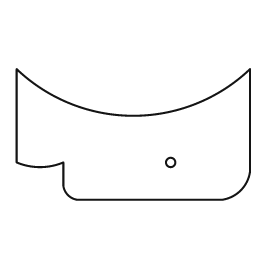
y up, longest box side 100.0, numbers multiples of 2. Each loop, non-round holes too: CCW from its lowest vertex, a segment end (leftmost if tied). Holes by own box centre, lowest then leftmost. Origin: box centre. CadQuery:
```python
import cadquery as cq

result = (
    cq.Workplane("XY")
    .moveTo(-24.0, -28.0)
    .lineTo(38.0, -28.0)
    .threePointArc((46.0, -24.0), (50.0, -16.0))
    .lineTo(50.0, 28.0)
    .threePointArc((0.0, 8.0), (-50.0, 28.0))
    .lineTo(-50.0, -12.0)
    .threePointArc((-40.0, -14.0), (-30.0, -12.0))
    .lineTo(-30.0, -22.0)
    .threePointArc((-28.0, -26.0), (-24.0, -28.0))
    .close()
    .moveTo(16.0, -12.0)
    .circle(2.0)
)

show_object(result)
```